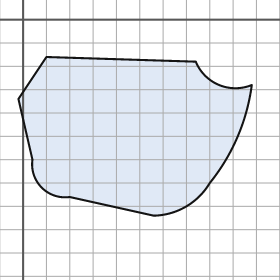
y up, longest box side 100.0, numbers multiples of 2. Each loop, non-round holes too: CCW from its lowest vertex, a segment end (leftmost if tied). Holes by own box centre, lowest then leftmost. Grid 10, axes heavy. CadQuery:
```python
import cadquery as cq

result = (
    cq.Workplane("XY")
    .moveTo(56.0, -84.0)
    .threePointArc((70.0, -80.0), (80.0, -70.0))
    .threePointArc((92.0, -50.0), (98.0, -28.0))
    .threePointArc((84.0, -28.0), (74.0, -18.0))
    .lineTo(10.0, -16.0)
    .lineTo(-2.0, -34.0)
    .lineTo(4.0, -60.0)
    .threePointArc((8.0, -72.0), (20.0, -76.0))
    .close()
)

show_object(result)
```